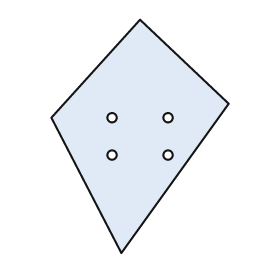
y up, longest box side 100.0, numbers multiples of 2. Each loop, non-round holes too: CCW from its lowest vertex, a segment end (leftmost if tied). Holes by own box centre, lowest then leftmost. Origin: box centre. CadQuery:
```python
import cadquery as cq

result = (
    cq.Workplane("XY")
    .moveTo(-8.0, -50.0)
    .lineTo(38.0, 14.0)
    .lineTo(0.0, 50.0)
    .lineTo(-38.0, 8.0)
    .close()
    .moveTo(-12.0, -8.0)
    .circle(2.0)
    .moveTo(12.0, -8.0)
    .circle(2.0)
    .moveTo(-12.0, 8.0)
    .circle(2.0)
    .moveTo(12.0, 8.0)
    .circle(2.0)
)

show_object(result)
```